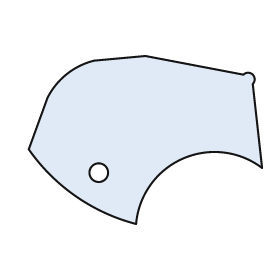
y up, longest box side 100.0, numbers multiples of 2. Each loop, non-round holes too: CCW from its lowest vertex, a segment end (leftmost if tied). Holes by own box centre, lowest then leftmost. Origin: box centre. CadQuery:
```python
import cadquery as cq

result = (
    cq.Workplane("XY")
    .moveTo(-4.0, -36.0)
    .threePointArc((16.0, -8.0), (50.0, -12.0))
    .lineTo(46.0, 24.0)
    .threePointArc((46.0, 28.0), (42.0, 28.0))
    .lineTo(0.0, 36.0)
    .lineTo(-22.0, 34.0)
    .threePointArc((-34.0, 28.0), (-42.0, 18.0))
    .lineTo(-50.0, -4.0)
    .threePointArc((-30.0, -24.0), (-4.0, -36.0))
    .close()
    .moveTo(-20.0, -14.0)
    .circle(4.0)
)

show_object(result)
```